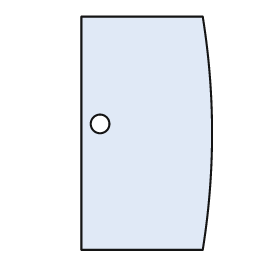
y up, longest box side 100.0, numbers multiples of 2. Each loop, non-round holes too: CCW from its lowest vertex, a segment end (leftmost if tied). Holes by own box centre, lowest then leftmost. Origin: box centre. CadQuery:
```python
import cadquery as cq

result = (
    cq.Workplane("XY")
    .moveTo(-28.0, -50.0)
    .lineTo(24.0, -50.0)
    .threePointArc((28.0, 0.0), (24.0, 50.0))
    .lineTo(-28.0, 50.0)
    .close()
    .moveTo(-20.0, 4.0)
    .circle(4.0)
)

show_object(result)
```